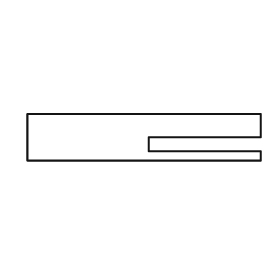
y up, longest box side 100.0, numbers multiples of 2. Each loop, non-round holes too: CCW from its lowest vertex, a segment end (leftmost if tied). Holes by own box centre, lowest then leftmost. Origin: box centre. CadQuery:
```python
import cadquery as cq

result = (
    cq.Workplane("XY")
    .moveTo(-50.0, -10.0)
    .lineTo(50.0, -10.0)
    .lineTo(50.0, -6.0)
    .lineTo(2.0, -6.0)
    .lineTo(2.0, 0.0)
    .lineTo(50.0, 0.0)
    .lineTo(50.0, 10.0)
    .lineTo(-50.0, 10.0)
    .close()
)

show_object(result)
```